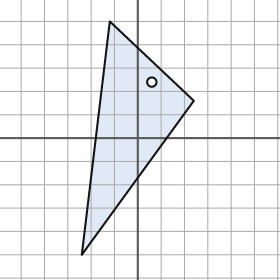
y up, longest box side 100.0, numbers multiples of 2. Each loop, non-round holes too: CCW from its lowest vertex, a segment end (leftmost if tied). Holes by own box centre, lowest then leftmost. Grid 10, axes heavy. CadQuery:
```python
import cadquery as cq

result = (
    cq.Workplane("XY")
    .moveTo(-24.0, -50.0)
    .lineTo(24.0, 16.0)
    .lineTo(-12.0, 50.0)
    .close()
    .moveTo(6.0, 24.0)
    .circle(2.0)
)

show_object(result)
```